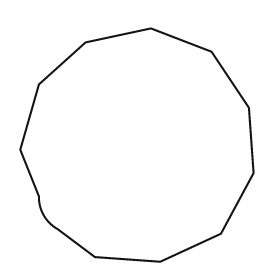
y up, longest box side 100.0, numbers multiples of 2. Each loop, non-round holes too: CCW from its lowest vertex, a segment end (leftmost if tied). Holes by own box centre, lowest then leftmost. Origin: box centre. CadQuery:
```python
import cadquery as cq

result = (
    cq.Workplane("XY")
    .moveTo(10.0, -50.0)
    .lineTo(36.0, -38.0)
    .lineTo(50.0, -12.0)
    .lineTo(48.0, 16.0)
    .lineTo(32.0, 40.0)
    .lineTo(6.0, 50.0)
    .lineTo(-22.0, 44.0)
    .lineTo(-42.0, 26.0)
    .lineTo(-50.0, -2.0)
    .lineTo(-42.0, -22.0)
    .threePointArc((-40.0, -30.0), (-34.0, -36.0))
    .lineTo(-18.0, -48.0)
    .close()
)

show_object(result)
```